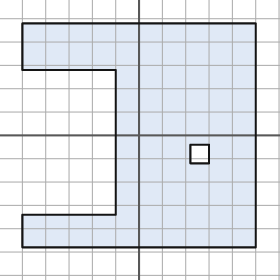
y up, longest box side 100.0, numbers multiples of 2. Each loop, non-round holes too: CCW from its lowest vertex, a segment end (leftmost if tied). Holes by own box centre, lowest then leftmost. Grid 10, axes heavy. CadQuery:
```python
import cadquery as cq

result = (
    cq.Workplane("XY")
    .moveTo(-50.0, -48.0)
    .lineTo(50.0, -48.0)
    .lineTo(50.0, 48.0)
    .lineTo(-50.0, 48.0)
    .lineTo(-50.0, 28.0)
    .lineTo(-10.0, 28.0)
    .lineTo(-10.0, -34.0)
    .lineTo(-50.0, -34.0)
    .close()
    .moveTo(22.0, -12.0)
    .lineTo(30.0, -12.0)
    .lineTo(30.0, -4.0)
    .lineTo(22.0, -4.0)
    .close()
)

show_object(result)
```